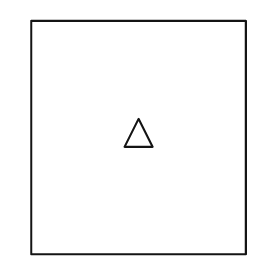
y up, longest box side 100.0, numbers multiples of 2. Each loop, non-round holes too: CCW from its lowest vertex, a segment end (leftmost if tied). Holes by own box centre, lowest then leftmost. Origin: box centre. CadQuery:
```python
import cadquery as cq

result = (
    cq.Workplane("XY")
    .moveTo(-46.0, -50.0)
    .lineTo(46.0, -50.0)
    .lineTo(46.0, 50.0)
    .lineTo(-46.0, 50.0)
    .close()
    .moveTo(-6.0, -4.0)
    .lineTo(6.0, -4.0)
    .lineTo(0.0, 8.0)
    .close()
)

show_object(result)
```